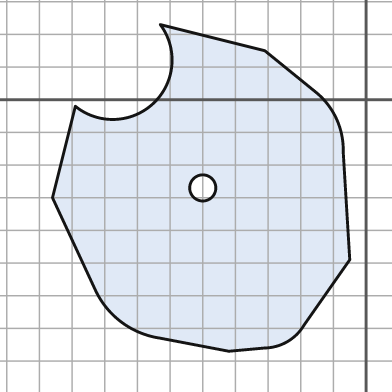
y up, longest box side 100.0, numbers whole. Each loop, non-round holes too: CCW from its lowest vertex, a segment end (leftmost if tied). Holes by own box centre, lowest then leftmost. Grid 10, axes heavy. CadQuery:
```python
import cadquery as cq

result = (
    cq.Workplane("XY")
    .moveTo(-42.0, -77.0)
    .lineTo(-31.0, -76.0)
    .threePointArc((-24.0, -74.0), (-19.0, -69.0))
    .lineTo(-5.0, -49.0)
    .lineTo(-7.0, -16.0)
    .threePointArc((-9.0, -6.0), (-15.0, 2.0))
    .lineTo(-31.0, 15.0)
    .lineTo(-63.0, 23.0)
    .threePointArc((-65.0, -1.0), (-89.0, -2.0))
    .lineTo(-96.0, -30.0)
    .lineTo(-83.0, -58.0)
    .threePointArc((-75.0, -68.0), (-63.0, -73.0))
    .close()
    .moveTo(-50.0, -27.0)
    .circle(4.0)
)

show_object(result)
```